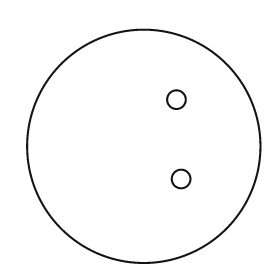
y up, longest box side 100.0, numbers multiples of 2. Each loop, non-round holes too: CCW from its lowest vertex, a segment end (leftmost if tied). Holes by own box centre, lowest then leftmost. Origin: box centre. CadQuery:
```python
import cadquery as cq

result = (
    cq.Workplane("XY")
    .moveTo(0.0, 0.0)
    .circle(50.0)
    .moveTo(16.0, -14.0)
    .circle(4.0)
    .moveTo(14.0, 20.0)
    .circle(4.0)
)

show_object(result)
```